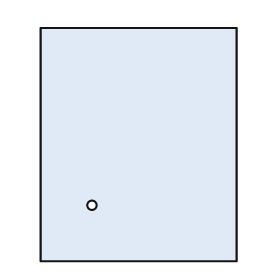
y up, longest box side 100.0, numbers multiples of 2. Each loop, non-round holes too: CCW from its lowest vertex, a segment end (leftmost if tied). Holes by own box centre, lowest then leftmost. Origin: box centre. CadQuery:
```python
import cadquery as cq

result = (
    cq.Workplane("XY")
    .moveTo(-42.0, -50.0)
    .lineTo(42.0, -50.0)
    .lineTo(42.0, 50.0)
    .lineTo(-42.0, 50.0)
    .close()
    .moveTo(-20.0, -26.0)
    .circle(2.0)
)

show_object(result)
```